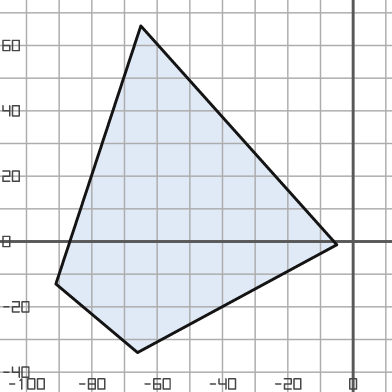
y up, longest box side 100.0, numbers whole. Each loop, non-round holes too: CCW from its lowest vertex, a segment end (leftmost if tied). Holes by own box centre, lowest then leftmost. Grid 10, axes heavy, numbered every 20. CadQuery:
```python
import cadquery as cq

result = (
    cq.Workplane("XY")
    .moveTo(-66.0, -34.0)
    .lineTo(-5.0, -1.0)
    .lineTo(-65.0, 66.0)
    .lineTo(-91.0, -13.0)
    .close()
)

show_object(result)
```